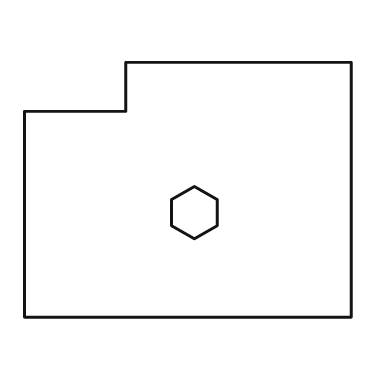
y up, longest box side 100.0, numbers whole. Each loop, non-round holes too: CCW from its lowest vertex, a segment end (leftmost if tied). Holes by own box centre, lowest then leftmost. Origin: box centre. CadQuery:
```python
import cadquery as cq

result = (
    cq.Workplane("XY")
    .moveTo(-50.0, -39.0)
    .lineTo(50.0, -39.0)
    .lineTo(50.0, 39.0)
    .lineTo(-19.0, 39.0)
    .lineTo(-19.0, 24.0)
    .lineTo(-50.0, 24.0)
    .close()
    .moveTo(2.0, -15.0)
    .lineTo(9.0, -11.0)
    .lineTo(9.0, -3.0)
    .lineTo(2.0, 1.0)
    .lineTo(-5.0, -3.0)
    .lineTo(-5.0, -11.0)
    .close()
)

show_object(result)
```